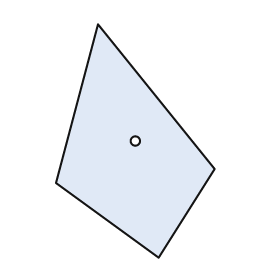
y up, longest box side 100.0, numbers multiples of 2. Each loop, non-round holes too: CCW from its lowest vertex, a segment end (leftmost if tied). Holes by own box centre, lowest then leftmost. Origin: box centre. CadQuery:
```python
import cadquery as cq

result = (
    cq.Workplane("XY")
    .moveTo(10.0, -50.0)
    .lineTo(34.0, -12.0)
    .lineTo(-16.0, 50.0)
    .lineTo(-34.0, -18.0)
    .close()
    .moveTo(0.0, 0.0)
    .circle(2.0)
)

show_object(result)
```